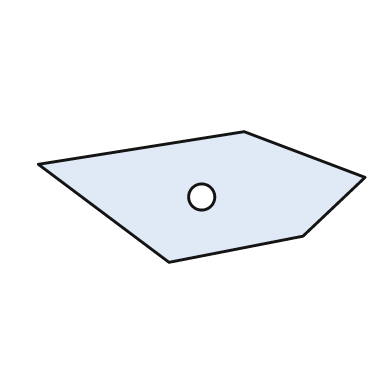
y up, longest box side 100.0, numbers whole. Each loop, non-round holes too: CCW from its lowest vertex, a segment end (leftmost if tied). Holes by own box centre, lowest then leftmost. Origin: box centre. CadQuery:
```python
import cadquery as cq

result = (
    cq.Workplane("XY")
    .moveTo(-10.0, -20.0)
    .lineTo(31.0, -12.0)
    .lineTo(50.0, 6.0)
    .lineTo(13.0, 20.0)
    .lineTo(-50.0, 10.0)
    .close()
    .moveTo(0.0, 0.0)
    .circle(4.0)
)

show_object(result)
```